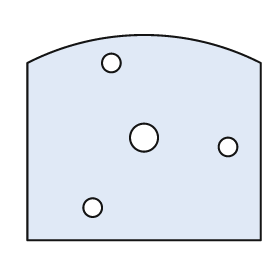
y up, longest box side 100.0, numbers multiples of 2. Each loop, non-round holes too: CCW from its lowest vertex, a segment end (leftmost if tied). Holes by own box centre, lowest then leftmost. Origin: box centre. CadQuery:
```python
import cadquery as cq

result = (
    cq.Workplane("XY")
    .moveTo(-50.0, -44.0)
    .lineTo(50.0, -44.0)
    .lineTo(50.0, 32.0)
    .threePointArc((0.0, 44.0), (-50.0, 32.0))
    .close()
    .moveTo(-22.0, -30.0)
    .circle(4.0)
    .moveTo(36.0, -4.0)
    .circle(4.0)
    .moveTo(0.0, 0.0)
    .circle(6.0)
    .moveTo(-14.0, 32.0)
    .circle(4.0)
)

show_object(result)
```